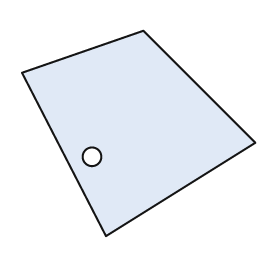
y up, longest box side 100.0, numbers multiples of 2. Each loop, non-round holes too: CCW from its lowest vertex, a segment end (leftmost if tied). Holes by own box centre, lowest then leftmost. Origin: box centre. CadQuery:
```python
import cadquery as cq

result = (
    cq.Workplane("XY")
    .moveTo(-14.0, -44.0)
    .lineTo(50.0, -4.0)
    .lineTo(2.0, 44.0)
    .lineTo(-50.0, 26.0)
    .close()
    .moveTo(-20.0, -10.0)
    .circle(4.0)
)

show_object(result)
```